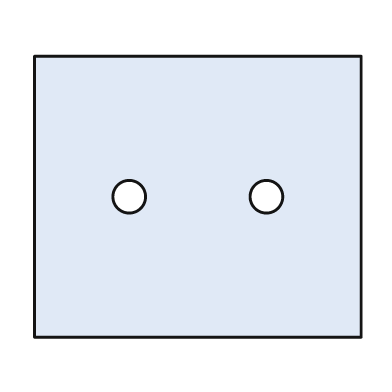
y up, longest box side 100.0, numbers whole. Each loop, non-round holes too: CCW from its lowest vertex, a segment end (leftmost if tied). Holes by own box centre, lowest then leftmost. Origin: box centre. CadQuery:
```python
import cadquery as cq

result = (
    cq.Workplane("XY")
    .moveTo(-50.0, -43.0)
    .lineTo(50.0, -43.0)
    .lineTo(50.0, 43.0)
    .lineTo(-50.0, 43.0)
    .close()
    .moveTo(-21.0, 0.0)
    .circle(5.0)
    .moveTo(21.0, 0.0)
    .circle(5.0)
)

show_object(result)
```